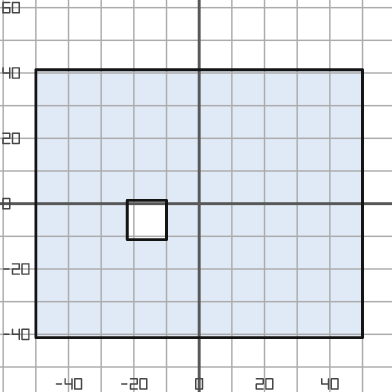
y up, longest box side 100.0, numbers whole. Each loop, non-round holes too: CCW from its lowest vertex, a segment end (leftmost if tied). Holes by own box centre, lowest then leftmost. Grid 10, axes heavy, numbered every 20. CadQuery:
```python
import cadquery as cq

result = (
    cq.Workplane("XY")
    .moveTo(-50.0, -41.0)
    .lineTo(50.0, -41.0)
    .lineTo(50.0, 41.0)
    .lineTo(-50.0, 41.0)
    .close()
    .moveTo(-22.0, -11.0)
    .lineTo(-10.0, -11.0)
    .lineTo(-10.0, 1.0)
    .lineTo(-22.0, 1.0)
    .close()
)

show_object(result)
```